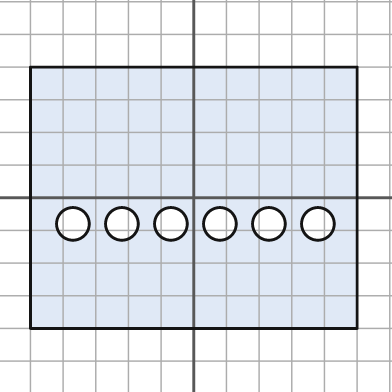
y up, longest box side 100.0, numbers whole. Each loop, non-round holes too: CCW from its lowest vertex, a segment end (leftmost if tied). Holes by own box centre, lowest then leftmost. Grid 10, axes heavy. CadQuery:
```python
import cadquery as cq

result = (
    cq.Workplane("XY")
    .moveTo(-50.0, -40.0)
    .lineTo(50.0, -40.0)
    .lineTo(50.0, 40.0)
    .lineTo(-50.0, 40.0)
    .close()
    .moveTo(-37.0, -8.0)
    .circle(5.0)
    .moveTo(-22.0, -8.0)
    .circle(5.0)
    .moveTo(-7.0, -8.0)
    .circle(5.0)
    .moveTo(8.0, -8.0)
    .circle(5.0)
    .moveTo(23.0, -8.0)
    .circle(5.0)
    .moveTo(38.0, -8.0)
    .circle(5.0)
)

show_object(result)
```